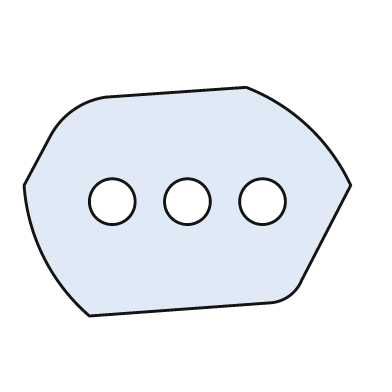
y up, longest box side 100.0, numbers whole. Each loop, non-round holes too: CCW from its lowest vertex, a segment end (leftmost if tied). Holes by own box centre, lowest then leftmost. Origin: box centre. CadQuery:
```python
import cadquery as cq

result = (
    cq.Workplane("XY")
    .moveTo(-30.0, -35.0)
    .lineTo(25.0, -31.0)
    .threePointArc((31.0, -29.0), (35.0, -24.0))
    .lineTo(50.0, 5.0)
    .threePointArc((37.0, 23.0), (18.0, 35.0))
    .lineTo(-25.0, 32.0)
    .threePointArc((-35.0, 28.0), (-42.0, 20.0))
    .lineTo(-50.0, 5.0)
    .threePointArc((-44.0, -17.0), (-30.0, -35.0))
    .close()
    .moveTo(-23.0, 0.0)
    .circle(7.0)
    .moveTo(0.0, 0.0)
    .circle(7.0)
    .moveTo(23.0, 0.0)
    .circle(7.0)
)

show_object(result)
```